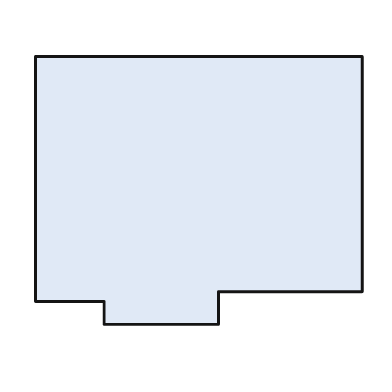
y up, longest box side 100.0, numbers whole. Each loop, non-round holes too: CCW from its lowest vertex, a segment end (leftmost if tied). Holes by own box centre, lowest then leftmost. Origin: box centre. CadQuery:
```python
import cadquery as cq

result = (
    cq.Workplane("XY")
    .moveTo(-29.0, -41.0)
    .lineTo(6.0, -41.0)
    .lineTo(6.0, -31.0)
    .lineTo(50.0, -31.0)
    .lineTo(50.0, 41.0)
    .lineTo(-50.0, 41.0)
    .lineTo(-50.0, -34.0)
    .lineTo(-29.0, -34.0)
    .close()
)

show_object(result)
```